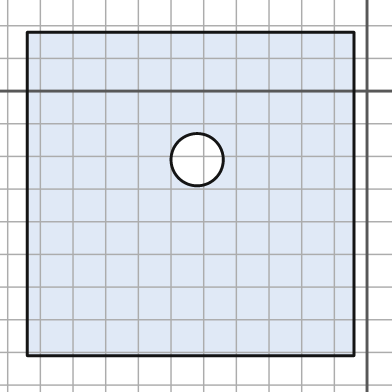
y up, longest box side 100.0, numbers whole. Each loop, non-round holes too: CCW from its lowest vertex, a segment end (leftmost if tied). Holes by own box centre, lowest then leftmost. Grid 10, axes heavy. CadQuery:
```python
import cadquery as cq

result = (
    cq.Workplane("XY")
    .moveTo(-104.0, -81.0)
    .lineTo(-4.0, -81.0)
    .lineTo(-4.0, 18.0)
    .lineTo(-104.0, 18.0)
    .close()
    .moveTo(-52.0, -21.0)
    .circle(8.0)
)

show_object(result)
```